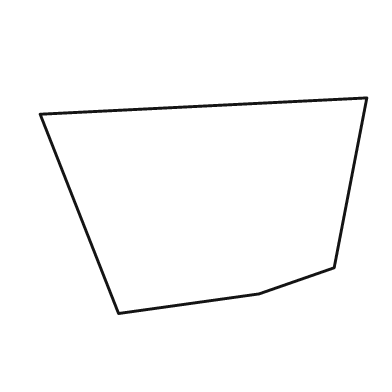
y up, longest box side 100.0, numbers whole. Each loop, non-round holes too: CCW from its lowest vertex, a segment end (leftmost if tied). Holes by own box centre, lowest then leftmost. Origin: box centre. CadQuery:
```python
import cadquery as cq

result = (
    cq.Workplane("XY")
    .moveTo(-26.0, -33.0)
    .lineTo(17.0, -27.0)
    .lineTo(40.0, -19.0)
    .lineTo(50.0, 33.0)
    .lineTo(-50.0, 28.0)
    .close()
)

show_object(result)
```